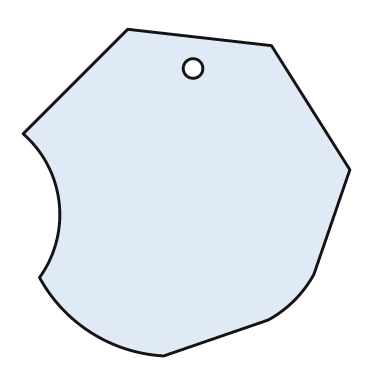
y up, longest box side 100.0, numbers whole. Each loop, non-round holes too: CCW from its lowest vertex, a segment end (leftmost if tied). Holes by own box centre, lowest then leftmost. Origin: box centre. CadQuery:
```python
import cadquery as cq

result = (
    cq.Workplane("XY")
    .moveTo(-7.0, -50.0)
    .lineTo(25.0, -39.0)
    .threePointArc((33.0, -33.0), (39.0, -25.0))
    .lineTo(50.0, 7.0)
    .lineTo(26.0, 45.0)
    .lineTo(-18.0, 50.0)
    .lineTo(-50.0, 18.0)
    .threePointArc((-39.0, -3.0), (-45.0, -26.0))
    .threePointArc((-29.0, -43.0), (-7.0, -50.0))
    .close()
    .moveTo(2.0, 38.0)
    .circle(3.0)
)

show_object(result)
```